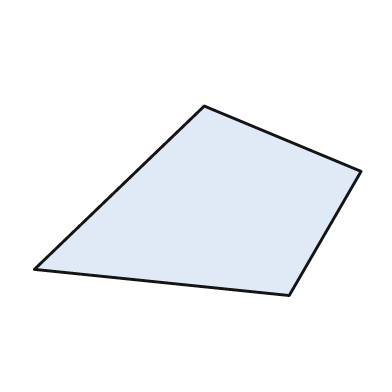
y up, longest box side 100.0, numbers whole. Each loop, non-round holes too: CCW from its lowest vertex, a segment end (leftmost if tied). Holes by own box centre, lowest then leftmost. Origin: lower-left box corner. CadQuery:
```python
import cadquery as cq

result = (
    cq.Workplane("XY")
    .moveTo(78.0, 0.0)
    .lineTo(100.0, 38.0)
    .lineTo(52.0, 58.0)
    .lineTo(0.0, 8.0)
    .close()
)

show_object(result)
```